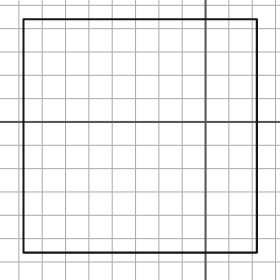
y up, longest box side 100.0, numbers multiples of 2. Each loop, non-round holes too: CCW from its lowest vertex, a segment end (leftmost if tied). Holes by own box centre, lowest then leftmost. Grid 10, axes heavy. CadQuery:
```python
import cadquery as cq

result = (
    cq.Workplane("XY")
    .moveTo(-78.0, -56.0)
    .lineTo(22.0, -56.0)
    .lineTo(22.0, 44.0)
    .lineTo(-78.0, 44.0)
    .close()
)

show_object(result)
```